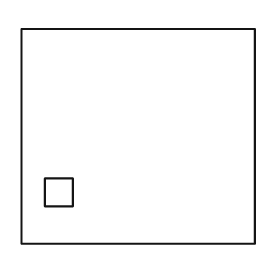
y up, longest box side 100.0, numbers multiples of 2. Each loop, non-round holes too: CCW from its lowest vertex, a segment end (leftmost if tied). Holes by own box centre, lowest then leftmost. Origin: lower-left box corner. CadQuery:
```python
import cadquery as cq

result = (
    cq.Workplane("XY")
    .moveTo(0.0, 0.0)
    .lineTo(100.0, 0.0)
    .lineTo(100.0, 92.0)
    .lineTo(0.0, 92.0)
    .close()
    .moveTo(10.0, 16.0)
    .lineTo(22.0, 16.0)
    .lineTo(22.0, 28.0)
    .lineTo(10.0, 28.0)
    .close()
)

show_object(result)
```